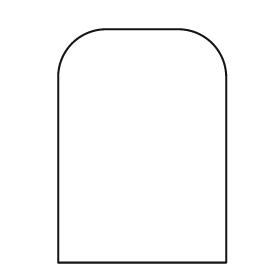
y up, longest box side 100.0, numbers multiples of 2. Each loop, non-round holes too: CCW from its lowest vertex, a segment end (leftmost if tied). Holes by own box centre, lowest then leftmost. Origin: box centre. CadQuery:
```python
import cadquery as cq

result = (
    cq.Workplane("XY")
    .moveTo(-36.0, -50.0)
    .lineTo(36.0, -50.0)
    .lineTo(36.0, 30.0)
    .threePointArc((30.0, 44.0), (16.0, 50.0))
    .lineTo(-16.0, 50.0)
    .threePointArc((-30.0, 44.0), (-36.0, 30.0))
    .close()
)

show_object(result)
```